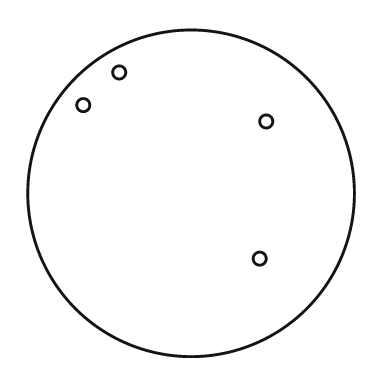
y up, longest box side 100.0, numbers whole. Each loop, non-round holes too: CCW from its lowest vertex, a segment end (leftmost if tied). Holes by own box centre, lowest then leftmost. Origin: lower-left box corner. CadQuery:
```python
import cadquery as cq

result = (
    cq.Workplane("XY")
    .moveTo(50.0, 50.0)
    .circle(50.0)
    .moveTo(71.0, 30.0)
    .circle(2.0)
    .moveTo(73.0, 72.0)
    .circle(2.0)
    .moveTo(17.0, 77.0)
    .circle(2.0)
    .moveTo(28.0, 87.0)
    .circle(2.0)
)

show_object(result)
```